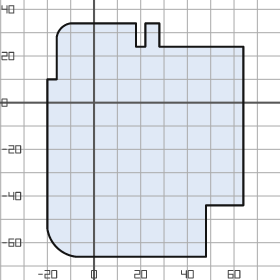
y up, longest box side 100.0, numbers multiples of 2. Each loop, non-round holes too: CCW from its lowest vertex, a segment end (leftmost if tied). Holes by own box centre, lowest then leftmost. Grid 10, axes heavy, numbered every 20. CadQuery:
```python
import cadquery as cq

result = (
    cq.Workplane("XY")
    .moveTo(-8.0, -66.0)
    .lineTo(48.0, -66.0)
    .lineTo(48.0, -44.0)
    .lineTo(64.0, -44.0)
    .lineTo(64.0, 24.0)
    .lineTo(28.0, 24.0)
    .lineTo(28.0, 34.0)
    .lineTo(22.0, 34.0)
    .lineTo(22.0, 24.0)
    .lineTo(18.0, 24.0)
    .lineTo(18.0, 34.0)
    .lineTo(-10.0, 34.0)
    .threePointArc((-14.0, 32.0), (-16.0, 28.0))
    .lineTo(-16.0, 10.0)
    .lineTo(-20.0, 10.0)
    .lineTo(-20.0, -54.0)
    .threePointArc((-16.0, -62.0), (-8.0, -66.0))
    .close()
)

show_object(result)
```